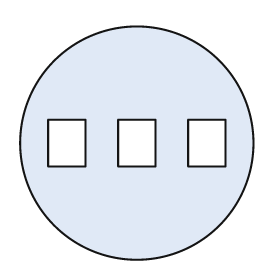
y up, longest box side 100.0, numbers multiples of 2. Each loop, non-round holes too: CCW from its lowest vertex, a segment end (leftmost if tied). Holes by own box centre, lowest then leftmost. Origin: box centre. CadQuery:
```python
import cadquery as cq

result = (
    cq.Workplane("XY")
    .moveTo(0.0, 0.0)
    .circle(50.0)
    .moveTo(-38.0, -10.0)
    .lineTo(-22.0, -10.0)
    .lineTo(-22.0, 10.0)
    .lineTo(-38.0, 10.0)
    .close()
    .moveTo(-8.0, -10.0)
    .lineTo(8.0, -10.0)
    .lineTo(8.0, 10.0)
    .lineTo(-8.0, 10.0)
    .close()
    .moveTo(22.0, -10.0)
    .lineTo(38.0, -10.0)
    .lineTo(38.0, 10.0)
    .lineTo(22.0, 10.0)
    .close()
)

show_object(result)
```